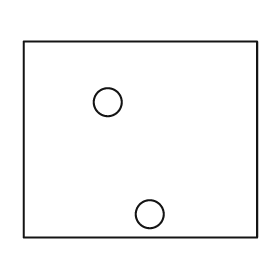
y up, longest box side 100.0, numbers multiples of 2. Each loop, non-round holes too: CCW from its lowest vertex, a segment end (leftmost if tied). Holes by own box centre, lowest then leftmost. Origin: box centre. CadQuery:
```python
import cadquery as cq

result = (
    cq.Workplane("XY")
    .moveTo(-50.0, -42.0)
    .lineTo(50.0, -42.0)
    .lineTo(50.0, 42.0)
    .lineTo(-50.0, 42.0)
    .close()
    .moveTo(4.0, -32.0)
    .circle(6.0)
    .moveTo(-14.0, 16.0)
    .circle(6.0)
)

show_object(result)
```